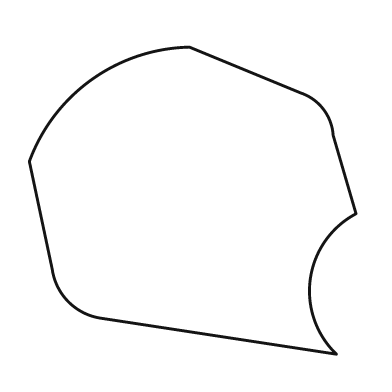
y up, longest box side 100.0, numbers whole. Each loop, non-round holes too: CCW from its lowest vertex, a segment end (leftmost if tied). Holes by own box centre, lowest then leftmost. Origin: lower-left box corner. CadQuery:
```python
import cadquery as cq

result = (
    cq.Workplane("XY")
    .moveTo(94.0, 0.0)
    .threePointArc((86.0, 23.0), (100.0, 43.0))
    .lineTo(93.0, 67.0)
    .threePointArc((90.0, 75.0), (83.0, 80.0))
    .lineTo(49.0, 94.0)
    .threePointArc((19.0, 84.0), (0.0, 59.0))
    .lineTo(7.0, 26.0)
    .threePointArc((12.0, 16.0), (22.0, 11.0))
    .close()
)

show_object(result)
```